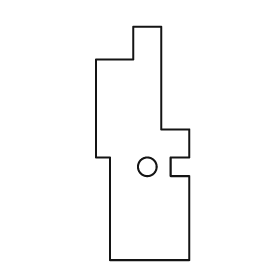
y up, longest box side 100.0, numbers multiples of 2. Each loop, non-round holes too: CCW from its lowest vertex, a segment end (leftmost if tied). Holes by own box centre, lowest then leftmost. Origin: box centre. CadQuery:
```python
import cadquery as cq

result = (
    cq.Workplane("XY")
    .moveTo(-14.0, -50.0)
    .lineTo(20.0, -50.0)
    .lineTo(20.0, -14.0)
    .lineTo(12.0, -14.0)
    .lineTo(12.0, -6.0)
    .lineTo(20.0, -6.0)
    .lineTo(20.0, 6.0)
    .lineTo(8.0, 6.0)
    .lineTo(8.0, 50.0)
    .lineTo(-4.0, 50.0)
    .lineTo(-4.0, 36.0)
    .lineTo(-20.0, 36.0)
    .lineTo(-20.0, -6.0)
    .lineTo(-14.0, -6.0)
    .close()
    .moveTo(2.0, -10.0)
    .circle(4.0)
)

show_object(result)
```